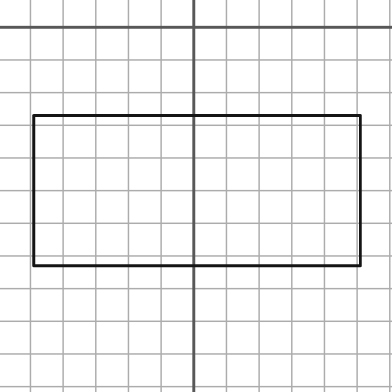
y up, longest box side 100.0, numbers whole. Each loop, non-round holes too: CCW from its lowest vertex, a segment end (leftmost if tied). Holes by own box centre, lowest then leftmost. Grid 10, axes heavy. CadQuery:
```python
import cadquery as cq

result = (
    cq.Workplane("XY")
    .moveTo(-49.0, -73.0)
    .lineTo(51.0, -73.0)
    .lineTo(51.0, -27.0)
    .lineTo(-49.0, -27.0)
    .close()
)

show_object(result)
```